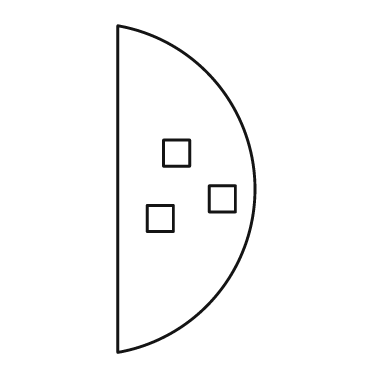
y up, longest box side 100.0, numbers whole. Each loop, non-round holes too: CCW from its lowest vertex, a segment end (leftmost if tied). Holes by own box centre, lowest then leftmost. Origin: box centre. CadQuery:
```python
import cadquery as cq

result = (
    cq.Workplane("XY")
    .moveTo(-21.0, -50.0)
    .threePointArc((21.0, 0.0), (-21.0, 50.0))
    .close()
    .moveTo(-12.0, -13.0)
    .lineTo(-4.0, -13.0)
    .lineTo(-4.0, -5.0)
    .lineTo(-12.0, -5.0)
    .close()
    .moveTo(7.0, -7.0)
    .lineTo(15.0, -7.0)
    .lineTo(15.0, 1.0)
    .lineTo(7.0, 1.0)
    .close()
    .moveTo(-7.0, 7.0)
    .lineTo(1.0, 7.0)
    .lineTo(1.0, 15.0)
    .lineTo(-7.0, 15.0)
    .close()
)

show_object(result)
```